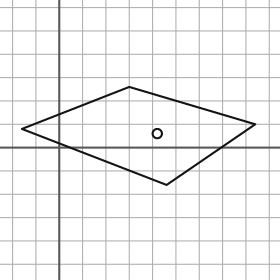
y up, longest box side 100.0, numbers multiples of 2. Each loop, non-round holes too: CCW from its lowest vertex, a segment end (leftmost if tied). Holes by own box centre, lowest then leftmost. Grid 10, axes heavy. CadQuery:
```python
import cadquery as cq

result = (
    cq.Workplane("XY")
    .moveTo(46.0, -16.0)
    .lineTo(84.0, 10.0)
    .lineTo(30.0, 26.0)
    .lineTo(-16.0, 8.0)
    .close()
    .moveTo(42.0, 6.0)
    .circle(2.0)
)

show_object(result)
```